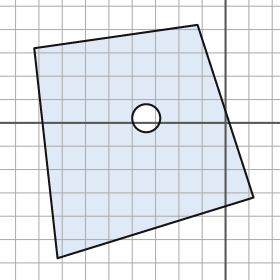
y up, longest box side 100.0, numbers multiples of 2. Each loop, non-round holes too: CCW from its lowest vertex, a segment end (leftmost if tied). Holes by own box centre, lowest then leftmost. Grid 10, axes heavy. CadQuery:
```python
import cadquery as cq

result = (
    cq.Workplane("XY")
    .moveTo(-72.0, -58.0)
    .lineTo(12.0, -32.0)
    .lineTo(-12.0, 42.0)
    .lineTo(-82.0, 32.0)
    .close()
    .moveTo(-34.0, 2.0)
    .circle(6.0)
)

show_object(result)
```